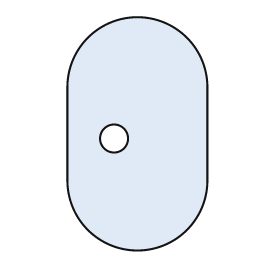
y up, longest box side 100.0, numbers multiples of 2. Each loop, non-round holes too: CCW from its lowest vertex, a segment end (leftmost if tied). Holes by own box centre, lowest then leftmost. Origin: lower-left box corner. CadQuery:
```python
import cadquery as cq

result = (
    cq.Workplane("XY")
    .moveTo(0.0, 30.0)
    .threePointArc((30.0, 0.0), (60.0, 30.0))
    .lineTo(60.0, 70.0)
    .threePointArc((30.0, 100.0), (0.0, 70.0))
    .close()
    .moveTo(20.0, 48.0)
    .circle(6.0)
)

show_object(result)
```